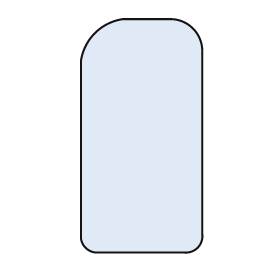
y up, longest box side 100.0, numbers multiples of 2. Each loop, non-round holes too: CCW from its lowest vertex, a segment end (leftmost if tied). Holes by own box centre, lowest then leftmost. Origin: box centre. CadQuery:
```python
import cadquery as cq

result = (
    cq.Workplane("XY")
    .moveTo(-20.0, -50.0)
    .lineTo(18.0, -50.0)
    .threePointArc((24.0, -48.0), (26.0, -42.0))
    .lineTo(26.0, 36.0)
    .threePointArc((22.0, 46.0), (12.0, 50.0))
    .lineTo(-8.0, 50.0)
    .threePointArc((-20.0, 44.0), (-26.0, 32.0))
    .lineTo(-26.0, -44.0)
    .threePointArc((-24.0, -48.0), (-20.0, -50.0))
    .close()
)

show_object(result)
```